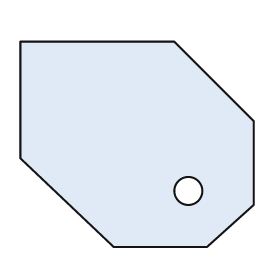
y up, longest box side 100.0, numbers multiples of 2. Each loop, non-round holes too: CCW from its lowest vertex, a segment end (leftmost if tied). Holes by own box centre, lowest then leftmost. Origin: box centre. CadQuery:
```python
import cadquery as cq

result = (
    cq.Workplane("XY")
    .moveTo(-10.0, -44.0)
    .lineTo(30.0, -44.0)
    .lineTo(50.0, -26.0)
    .lineTo(50.0, 10.0)
    .lineTo(16.0, 44.0)
    .lineTo(-50.0, 44.0)
    .lineTo(-50.0, -6.0)
    .close()
    .moveTo(22.0, -20.0)
    .circle(6.0)
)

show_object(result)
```